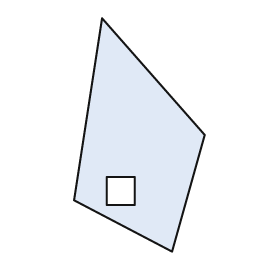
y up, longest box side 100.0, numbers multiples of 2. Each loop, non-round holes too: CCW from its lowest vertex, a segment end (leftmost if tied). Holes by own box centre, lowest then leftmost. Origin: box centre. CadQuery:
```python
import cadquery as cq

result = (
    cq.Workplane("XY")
    .moveTo(14.0, -50.0)
    .lineTo(28.0, 0.0)
    .lineTo(-16.0, 50.0)
    .lineTo(-28.0, -28.0)
    .close()
    .moveTo(-14.0, -30.0)
    .lineTo(-2.0, -30.0)
    .lineTo(-2.0, -18.0)
    .lineTo(-14.0, -18.0)
    .close()
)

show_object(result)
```